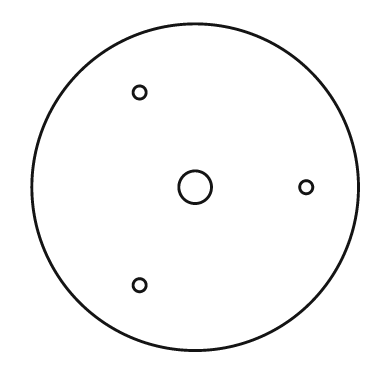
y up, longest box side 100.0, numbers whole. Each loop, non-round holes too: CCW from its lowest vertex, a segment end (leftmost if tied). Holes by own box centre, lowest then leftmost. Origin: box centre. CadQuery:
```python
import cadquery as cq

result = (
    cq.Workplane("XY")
    .moveTo(0.0, 0.0)
    .circle(50.0)
    .moveTo(-17.0, -30.0)
    .circle(2.0)
    .moveTo(0.0, 0.0)
    .circle(5.0)
    .moveTo(34.0, 0.0)
    .circle(2.0)
    .moveTo(-17.0, 29.0)
    .circle(2.0)
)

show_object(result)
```